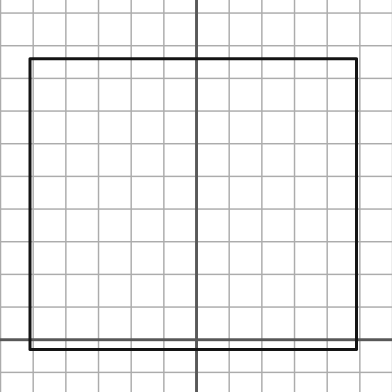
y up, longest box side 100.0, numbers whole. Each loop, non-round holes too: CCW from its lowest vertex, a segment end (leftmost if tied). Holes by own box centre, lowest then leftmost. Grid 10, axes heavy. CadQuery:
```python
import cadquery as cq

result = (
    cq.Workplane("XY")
    .moveTo(-51.0, -3.0)
    .lineTo(49.0, -3.0)
    .lineTo(49.0, 86.0)
    .lineTo(-51.0, 86.0)
    .close()
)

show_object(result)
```